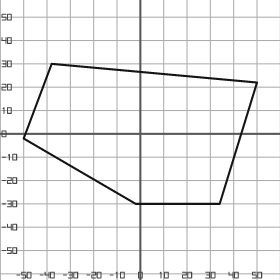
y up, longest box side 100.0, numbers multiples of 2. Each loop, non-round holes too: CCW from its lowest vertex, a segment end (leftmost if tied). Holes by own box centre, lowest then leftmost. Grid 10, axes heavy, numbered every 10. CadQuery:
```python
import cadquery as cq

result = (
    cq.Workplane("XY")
    .moveTo(-2.0, -30.0)
    .lineTo(34.0, -30.0)
    .lineTo(50.0, 22.0)
    .lineTo(-38.0, 30.0)
    .lineTo(-50.0, -2.0)
    .close()
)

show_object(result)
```